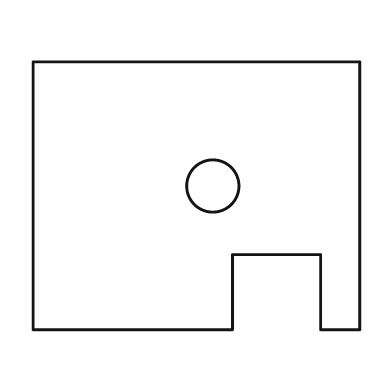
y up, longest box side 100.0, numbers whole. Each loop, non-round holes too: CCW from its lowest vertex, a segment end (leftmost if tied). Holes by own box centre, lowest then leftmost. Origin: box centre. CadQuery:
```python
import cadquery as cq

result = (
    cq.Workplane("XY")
    .moveTo(-50.0, -41.0)
    .lineTo(11.0, -41.0)
    .lineTo(11.0, -18.0)
    .lineTo(38.0, -18.0)
    .lineTo(38.0, -41.0)
    .lineTo(50.0, -41.0)
    .lineTo(50.0, 41.0)
    .lineTo(-50.0, 41.0)
    .close()
    .moveTo(5.0, 3.0)
    .circle(8.0)
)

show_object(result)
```